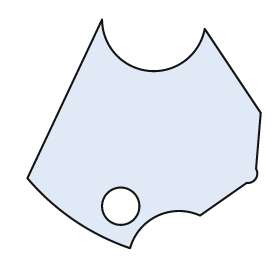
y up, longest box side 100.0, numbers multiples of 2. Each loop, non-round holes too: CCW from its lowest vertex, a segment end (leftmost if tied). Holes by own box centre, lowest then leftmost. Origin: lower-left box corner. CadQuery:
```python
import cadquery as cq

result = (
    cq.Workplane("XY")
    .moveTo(44.0, 0.0)
    .threePointArc((56.0, 14.0), (74.0, 14.0))
    .lineTo(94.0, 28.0)
    .threePointArc((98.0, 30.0), (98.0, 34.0))
    .lineTo(100.0, 58.0)
    .lineTo(76.0, 94.0)
    .threePointArc((52.0, 76.0), (32.0, 98.0))
    .lineTo(0.0, 30.0)
    .threePointArc((20.0, 12.0), (44.0, 0.0))
    .close()
    .moveTo(40.0, 18.0)
    .circle(8.0)
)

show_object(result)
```